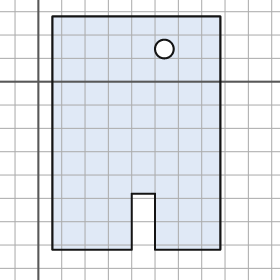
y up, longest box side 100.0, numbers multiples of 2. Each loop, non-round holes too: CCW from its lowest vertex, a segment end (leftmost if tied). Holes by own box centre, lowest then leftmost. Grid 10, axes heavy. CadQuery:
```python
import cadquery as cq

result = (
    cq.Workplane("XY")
    .moveTo(6.0, -72.0)
    .lineTo(40.0, -72.0)
    .lineTo(40.0, -48.0)
    .lineTo(50.0, -48.0)
    .lineTo(50.0, -72.0)
    .lineTo(78.0, -72.0)
    .lineTo(78.0, 28.0)
    .lineTo(6.0, 28.0)
    .close()
    .moveTo(54.0, 14.0)
    .circle(4.0)
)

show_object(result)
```